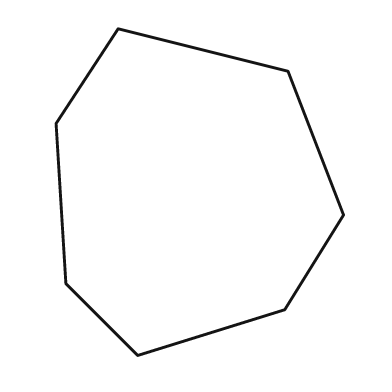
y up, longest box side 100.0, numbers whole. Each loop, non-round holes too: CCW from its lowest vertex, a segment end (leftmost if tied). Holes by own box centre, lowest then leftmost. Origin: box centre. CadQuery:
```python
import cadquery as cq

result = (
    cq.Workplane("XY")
    .moveTo(-19.0, -50.0)
    .lineTo(26.0, -36.0)
    .lineTo(44.0, -7.0)
    .lineTo(27.0, 37.0)
    .lineTo(-25.0, 50.0)
    .lineTo(-44.0, 21.0)
    .lineTo(-41.0, -28.0)
    .close()
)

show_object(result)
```